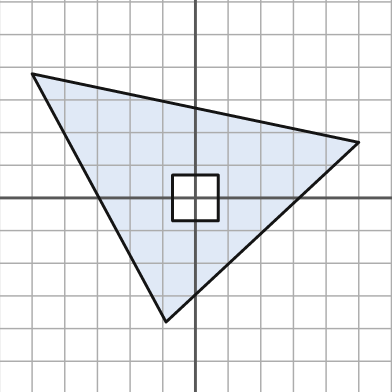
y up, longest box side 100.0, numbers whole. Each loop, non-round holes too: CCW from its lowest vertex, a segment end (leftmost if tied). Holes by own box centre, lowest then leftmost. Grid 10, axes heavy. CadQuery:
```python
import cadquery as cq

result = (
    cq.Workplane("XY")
    .moveTo(-9.0, -38.0)
    .lineTo(50.0, 17.0)
    .lineTo(-50.0, 38.0)
    .close()
    .moveTo(-7.0, -7.0)
    .lineTo(7.0, -7.0)
    .lineTo(7.0, 7.0)
    .lineTo(-7.0, 7.0)
    .close()
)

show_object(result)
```